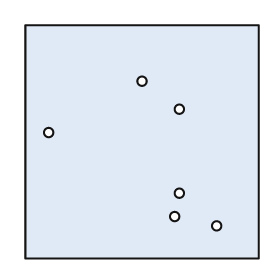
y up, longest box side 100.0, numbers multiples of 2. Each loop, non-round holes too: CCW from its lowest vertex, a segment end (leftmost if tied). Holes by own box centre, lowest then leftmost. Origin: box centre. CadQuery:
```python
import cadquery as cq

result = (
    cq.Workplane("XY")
    .moveTo(-50.0, -50.0)
    .lineTo(50.0, -50.0)
    .lineTo(50.0, 50.0)
    .lineTo(-50.0, 50.0)
    .close()
    .moveTo(32.0, -36.0)
    .circle(2.0)
    .moveTo(14.0, -32.0)
    .circle(2.0)
    .moveTo(16.0, -22.0)
    .circle(2.0)
    .moveTo(-40.0, 4.0)
    .circle(2.0)
    .moveTo(16.0, 14.0)
    .circle(2.0)
    .moveTo(0.0, 26.0)
    .circle(2.0)
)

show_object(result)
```